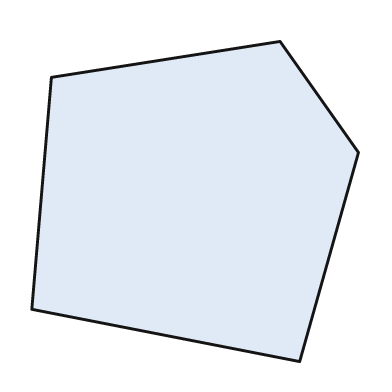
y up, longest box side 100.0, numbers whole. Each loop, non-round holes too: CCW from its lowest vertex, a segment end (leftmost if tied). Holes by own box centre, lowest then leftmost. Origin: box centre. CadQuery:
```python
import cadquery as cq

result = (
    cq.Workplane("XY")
    .moveTo(32.0, -49.0)
    .lineTo(50.0, 15.0)
    .lineTo(26.0, 49.0)
    .lineTo(-44.0, 38.0)
    .lineTo(-50.0, -33.0)
    .close()
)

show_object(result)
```